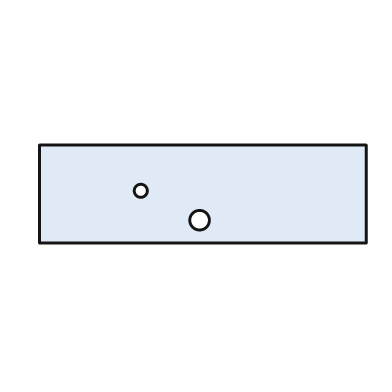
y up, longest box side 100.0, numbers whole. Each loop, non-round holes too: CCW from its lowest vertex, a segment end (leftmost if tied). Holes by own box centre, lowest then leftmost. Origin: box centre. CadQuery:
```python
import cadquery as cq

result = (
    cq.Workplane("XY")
    .moveTo(-50.0, -15.0)
    .lineTo(50.0, -15.0)
    .lineTo(50.0, 15.0)
    .lineTo(-50.0, 15.0)
    .close()
    .moveTo(-1.0, -8.0)
    .circle(3.0)
    .moveTo(-19.0, 1.0)
    .circle(2.0)
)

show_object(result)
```